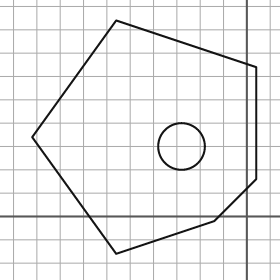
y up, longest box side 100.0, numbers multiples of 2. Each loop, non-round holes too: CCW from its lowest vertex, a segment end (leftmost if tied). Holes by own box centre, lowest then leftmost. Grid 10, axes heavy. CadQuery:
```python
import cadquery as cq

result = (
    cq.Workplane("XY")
    .moveTo(-56.0, -16.0)
    .lineTo(-14.0, -2.0)
    .lineTo(4.0, 16.0)
    .lineTo(4.0, 64.0)
    .lineTo(-56.0, 84.0)
    .lineTo(-92.0, 34.0)
    .close()
    .moveTo(-28.0, 30.0)
    .circle(10.0)
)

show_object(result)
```